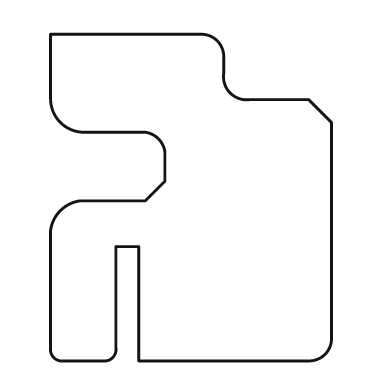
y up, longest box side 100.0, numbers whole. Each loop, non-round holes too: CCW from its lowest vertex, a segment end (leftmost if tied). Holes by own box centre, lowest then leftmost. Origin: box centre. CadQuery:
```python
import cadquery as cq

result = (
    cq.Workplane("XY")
    .moveTo(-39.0, -50.0)
    .lineTo(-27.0, -50.0)
    .threePointArc((-24.0, -49.0), (-23.0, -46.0))
    .lineTo(-23.0, -15.0)
    .lineTo(-16.0, -15.0)
    .lineTo(-16.0, -50.0)
    .lineTo(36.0, -50.0)
    .threePointArc((41.0, -48.0), (43.0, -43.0))
    .lineTo(43.0, 23.0)
    .lineTo(36.0, 30.0)
    .lineTo(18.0, 30.0)
    .threePointArc((12.0, 32.0), (10.0, 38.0))
    .lineTo(10.0, 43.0)
    .threePointArc((8.0, 48.0), (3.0, 50.0))
    .lineTo(-43.0, 50.0)
    .lineTo(-43.0, 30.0)
    .threePointArc((-40.0, 23.0), (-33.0, 20.0))
    .lineTo(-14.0, 20.0)
    .threePointArc((-10.0, 18.0), (-8.0, 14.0))
    .lineTo(-8.0, 5.0)
    .lineTo(-14.0, -1.0)
    .lineTo(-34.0, -1.0)
    .threePointArc((-40.0, -4.0), (-43.0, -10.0))
    .lineTo(-43.0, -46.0)
    .threePointArc((-42.0, -49.0), (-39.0, -50.0))
    .close()
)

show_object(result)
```